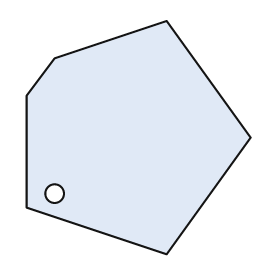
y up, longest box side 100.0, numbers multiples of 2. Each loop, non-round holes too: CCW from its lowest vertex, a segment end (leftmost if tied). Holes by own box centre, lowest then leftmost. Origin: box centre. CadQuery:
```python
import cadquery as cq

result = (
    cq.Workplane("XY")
    .moveTo(12.0, -50.0)
    .lineTo(48.0, 0.0)
    .lineTo(12.0, 50.0)
    .lineTo(-36.0, 34.0)
    .lineTo(-48.0, 18.0)
    .lineTo(-48.0, -30.0)
    .close()
    .moveTo(-36.0, -24.0)
    .circle(4.0)
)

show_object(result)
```